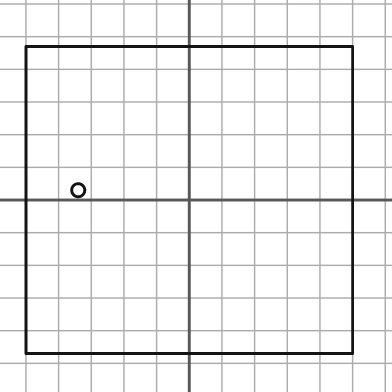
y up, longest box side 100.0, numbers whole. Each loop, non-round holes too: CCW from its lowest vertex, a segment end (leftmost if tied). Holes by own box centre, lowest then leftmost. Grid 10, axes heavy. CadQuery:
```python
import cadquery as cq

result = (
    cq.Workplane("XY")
    .moveTo(-50.0, -47.0)
    .lineTo(50.0, -47.0)
    .lineTo(50.0, 47.0)
    .lineTo(-50.0, 47.0)
    .close()
    .moveTo(-34.0, 3.0)
    .circle(2.0)
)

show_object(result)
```